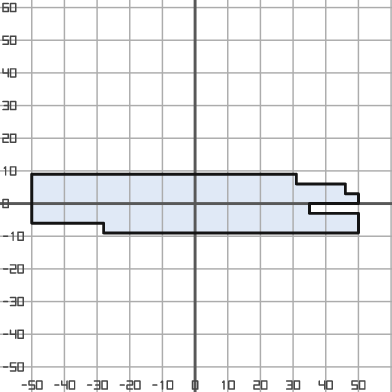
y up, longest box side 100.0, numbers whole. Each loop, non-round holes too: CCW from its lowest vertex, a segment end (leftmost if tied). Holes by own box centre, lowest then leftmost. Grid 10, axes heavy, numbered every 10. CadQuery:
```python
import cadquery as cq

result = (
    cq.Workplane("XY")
    .moveTo(-28.0, -9.0)
    .lineTo(50.0, -9.0)
    .lineTo(50.0, -3.0)
    .lineTo(35.0, -3.0)
    .lineTo(35.0, 0.0)
    .lineTo(50.0, 0.0)
    .lineTo(50.0, 3.0)
    .lineTo(46.0, 3.0)
    .lineTo(46.0, 6.0)
    .lineTo(31.0, 6.0)
    .lineTo(31.0, 9.0)
    .lineTo(-50.0, 9.0)
    .lineTo(-50.0, -6.0)
    .lineTo(-28.0, -6.0)
    .close()
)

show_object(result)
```